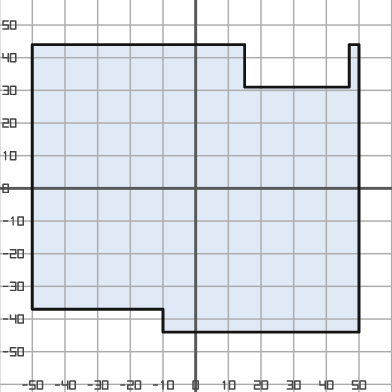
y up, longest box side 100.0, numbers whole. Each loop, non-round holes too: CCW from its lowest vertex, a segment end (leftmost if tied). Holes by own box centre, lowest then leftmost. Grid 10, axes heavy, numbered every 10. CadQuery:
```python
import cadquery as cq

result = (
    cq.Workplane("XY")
    .moveTo(-10.0, -44.0)
    .lineTo(50.0, -44.0)
    .lineTo(50.0, 44.0)
    .lineTo(47.0, 44.0)
    .lineTo(47.0, 31.0)
    .lineTo(15.0, 31.0)
    .lineTo(15.0, 44.0)
    .lineTo(-50.0, 44.0)
    .lineTo(-50.0, -37.0)
    .lineTo(-10.0, -37.0)
    .close()
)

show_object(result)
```